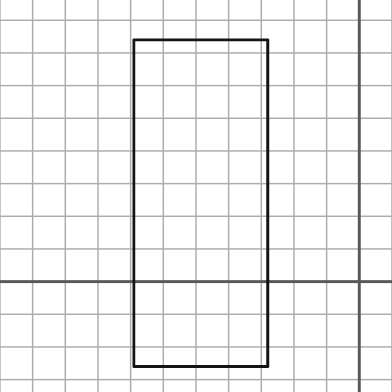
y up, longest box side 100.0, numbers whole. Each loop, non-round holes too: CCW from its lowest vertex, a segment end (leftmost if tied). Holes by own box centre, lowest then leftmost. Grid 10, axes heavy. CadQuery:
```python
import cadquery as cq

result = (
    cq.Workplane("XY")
    .moveTo(-69.0, -26.0)
    .lineTo(-28.0, -26.0)
    .lineTo(-28.0, 74.0)
    .lineTo(-69.0, 74.0)
    .close()
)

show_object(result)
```